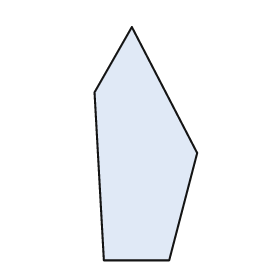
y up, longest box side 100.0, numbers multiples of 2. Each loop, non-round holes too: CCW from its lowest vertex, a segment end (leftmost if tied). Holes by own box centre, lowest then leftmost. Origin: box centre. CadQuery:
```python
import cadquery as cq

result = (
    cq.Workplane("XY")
    .moveTo(-18.0, -50.0)
    .lineTo(10.0, -50.0)
    .lineTo(22.0, -4.0)
    .lineTo(-6.0, 50.0)
    .lineTo(-22.0, 22.0)
    .close()
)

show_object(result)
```